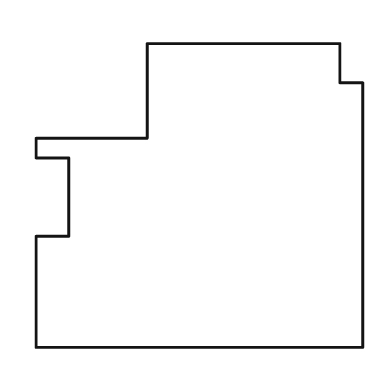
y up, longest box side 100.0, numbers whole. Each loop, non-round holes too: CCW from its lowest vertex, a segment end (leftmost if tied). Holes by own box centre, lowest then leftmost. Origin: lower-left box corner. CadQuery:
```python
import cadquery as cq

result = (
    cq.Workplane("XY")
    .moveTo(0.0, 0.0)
    .lineTo(100.0, 0.0)
    .lineTo(100.0, 81.0)
    .lineTo(93.0, 81.0)
    .lineTo(93.0, 93.0)
    .lineTo(34.0, 93.0)
    .lineTo(34.0, 64.0)
    .lineTo(0.0, 64.0)
    .lineTo(0.0, 58.0)
    .lineTo(10.0, 58.0)
    .lineTo(10.0, 34.0)
    .lineTo(0.0, 34.0)
    .close()
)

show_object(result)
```